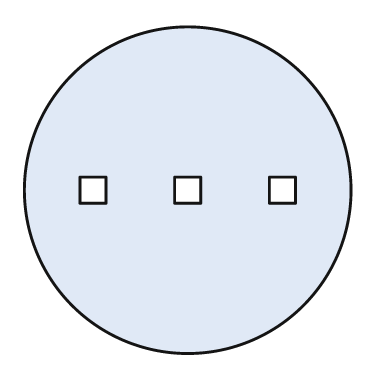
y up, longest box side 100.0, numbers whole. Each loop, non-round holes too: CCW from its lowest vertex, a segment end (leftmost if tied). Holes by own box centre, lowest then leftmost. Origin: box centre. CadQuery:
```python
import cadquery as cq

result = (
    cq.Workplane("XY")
    .moveTo(0.0, 0.0)
    .circle(50.0)
    .moveTo(-33.0, -4.0)
    .lineTo(-25.0, -4.0)
    .lineTo(-25.0, 4.0)
    .lineTo(-33.0, 4.0)
    .close()
    .moveTo(-4.0, -4.0)
    .lineTo(4.0, -4.0)
    .lineTo(4.0, 4.0)
    .lineTo(-4.0, 4.0)
    .close()
    .moveTo(25.0, -4.0)
    .lineTo(33.0, -4.0)
    .lineTo(33.0, 4.0)
    .lineTo(25.0, 4.0)
    .close()
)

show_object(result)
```